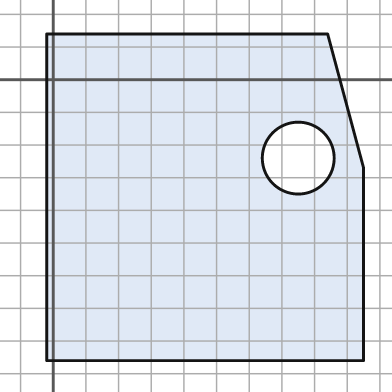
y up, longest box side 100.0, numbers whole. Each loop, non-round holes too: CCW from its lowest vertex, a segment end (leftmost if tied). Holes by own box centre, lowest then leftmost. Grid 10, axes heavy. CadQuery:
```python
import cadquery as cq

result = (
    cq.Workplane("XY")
    .moveTo(-2.0, -86.0)
    .lineTo(95.0, -86.0)
    .lineTo(95.0, -27.0)
    .lineTo(84.0, 14.0)
    .lineTo(-2.0, 14.0)
    .close()
    .moveTo(75.0, -24.0)
    .circle(11.0)
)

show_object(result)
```